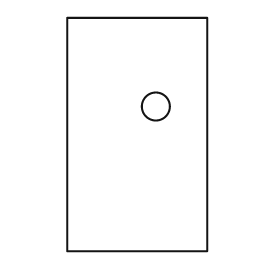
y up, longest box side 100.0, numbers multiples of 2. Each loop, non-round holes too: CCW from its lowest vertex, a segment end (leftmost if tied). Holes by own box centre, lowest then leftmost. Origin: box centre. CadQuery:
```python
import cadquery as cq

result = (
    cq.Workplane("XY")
    .moveTo(-30.0, -50.0)
    .lineTo(30.0, -50.0)
    .lineTo(30.0, 50.0)
    .lineTo(-30.0, 50.0)
    .close()
    .moveTo(8.0, 12.0)
    .circle(6.0)
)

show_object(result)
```